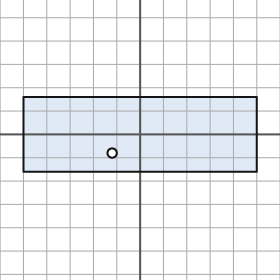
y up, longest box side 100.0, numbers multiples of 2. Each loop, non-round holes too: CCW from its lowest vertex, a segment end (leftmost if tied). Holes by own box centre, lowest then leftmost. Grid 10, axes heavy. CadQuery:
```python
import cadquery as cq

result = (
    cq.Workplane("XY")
    .moveTo(-50.0, -16.0)
    .lineTo(50.0, -16.0)
    .lineTo(50.0, 16.0)
    .lineTo(-50.0, 16.0)
    .close()
    .moveTo(-12.0, -8.0)
    .circle(2.0)
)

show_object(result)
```